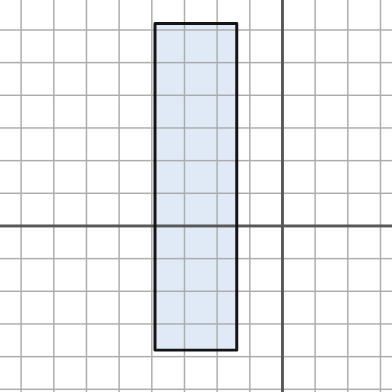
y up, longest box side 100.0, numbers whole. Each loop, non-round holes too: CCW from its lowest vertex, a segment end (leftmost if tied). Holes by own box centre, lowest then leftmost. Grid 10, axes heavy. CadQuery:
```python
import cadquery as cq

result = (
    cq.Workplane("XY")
    .moveTo(-39.0, -38.0)
    .lineTo(-14.0, -38.0)
    .lineTo(-14.0, 62.0)
    .lineTo(-39.0, 62.0)
    .close()
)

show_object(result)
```